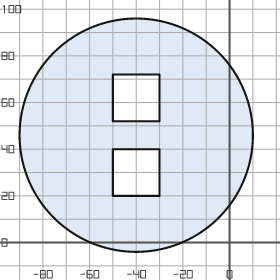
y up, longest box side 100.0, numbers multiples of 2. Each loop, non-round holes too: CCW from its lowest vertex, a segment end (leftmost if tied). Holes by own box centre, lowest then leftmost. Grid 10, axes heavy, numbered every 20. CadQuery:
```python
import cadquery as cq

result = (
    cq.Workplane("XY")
    .moveTo(-40.0, 46.0)
    .circle(50.0)
    .moveTo(-50.0, 20.0)
    .lineTo(-30.0, 20.0)
    .lineTo(-30.0, 40.0)
    .lineTo(-50.0, 40.0)
    .close()
    .moveTo(-50.0, 52.0)
    .lineTo(-30.0, 52.0)
    .lineTo(-30.0, 72.0)
    .lineTo(-50.0, 72.0)
    .close()
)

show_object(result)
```